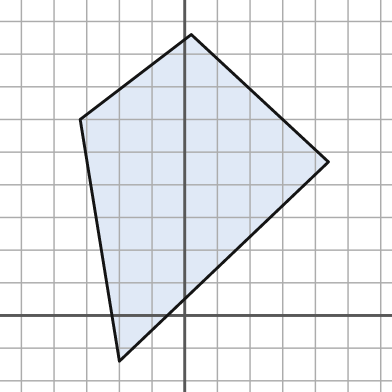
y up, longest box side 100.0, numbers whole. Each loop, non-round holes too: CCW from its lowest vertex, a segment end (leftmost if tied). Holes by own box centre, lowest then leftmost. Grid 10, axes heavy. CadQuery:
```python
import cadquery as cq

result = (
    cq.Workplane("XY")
    .moveTo(-20.0, -14.0)
    .lineTo(44.0, 47.0)
    .lineTo(2.0, 86.0)
    .lineTo(-32.0, 60.0)
    .close()
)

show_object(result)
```